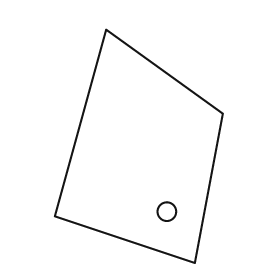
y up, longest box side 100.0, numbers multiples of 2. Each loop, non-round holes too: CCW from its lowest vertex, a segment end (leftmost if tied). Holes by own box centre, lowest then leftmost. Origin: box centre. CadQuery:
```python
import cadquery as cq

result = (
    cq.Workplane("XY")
    .moveTo(24.0, -50.0)
    .lineTo(36.0, 14.0)
    .lineTo(-14.0, 50.0)
    .lineTo(-36.0, -30.0)
    .close()
    .moveTo(12.0, -28.0)
    .circle(4.0)
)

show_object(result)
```